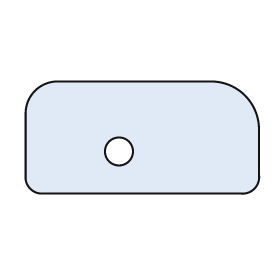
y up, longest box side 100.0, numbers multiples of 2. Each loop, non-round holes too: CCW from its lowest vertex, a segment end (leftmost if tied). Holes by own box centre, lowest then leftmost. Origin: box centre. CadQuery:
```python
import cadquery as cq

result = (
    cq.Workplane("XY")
    .moveTo(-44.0, -24.0)
    .lineTo(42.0, -24.0)
    .threePointArc((48.0, -22.0), (50.0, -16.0))
    .lineTo(50.0, 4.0)
    .threePointArc((44.0, 18.0), (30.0, 24.0))
    .lineTo(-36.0, 24.0)
    .threePointArc((-46.0, 20.0), (-50.0, 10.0))
    .lineTo(-50.0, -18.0)
    .threePointArc((-48.0, -22.0), (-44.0, -24.0))
    .close()
    .moveTo(-10.0, -6.0)
    .circle(6.0)
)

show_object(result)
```